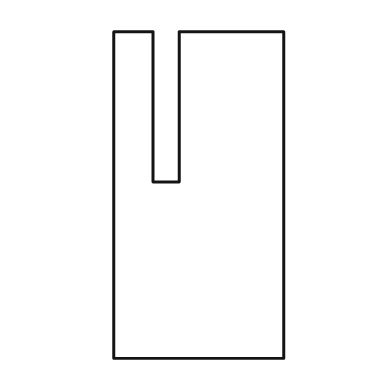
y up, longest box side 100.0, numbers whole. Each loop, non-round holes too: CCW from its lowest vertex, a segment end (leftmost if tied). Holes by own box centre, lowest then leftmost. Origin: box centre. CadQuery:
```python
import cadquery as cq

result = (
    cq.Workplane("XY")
    .moveTo(-26.0, -50.0)
    .lineTo(26.0, -50.0)
    .lineTo(26.0, 50.0)
    .lineTo(-6.0, 50.0)
    .lineTo(-6.0, 4.0)
    .lineTo(-14.0, 4.0)
    .lineTo(-14.0, 50.0)
    .lineTo(-26.0, 50.0)
    .close()
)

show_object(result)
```